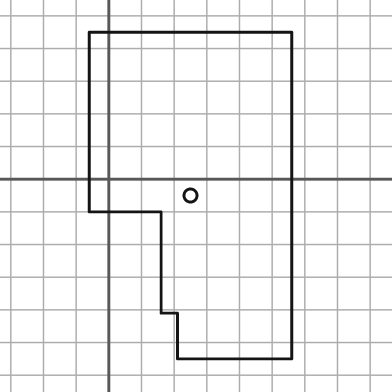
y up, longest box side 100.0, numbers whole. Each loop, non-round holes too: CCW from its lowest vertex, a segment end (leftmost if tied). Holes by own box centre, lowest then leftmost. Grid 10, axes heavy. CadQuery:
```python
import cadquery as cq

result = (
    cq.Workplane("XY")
    .moveTo(21.0, -55.0)
    .lineTo(56.0, -55.0)
    .lineTo(56.0, 45.0)
    .lineTo(-6.0, 45.0)
    .lineTo(-6.0, -10.0)
    .lineTo(16.0, -10.0)
    .lineTo(16.0, -41.0)
    .lineTo(21.0, -41.0)
    .close()
    .moveTo(25.0, -5.0)
    .circle(2.0)
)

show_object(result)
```